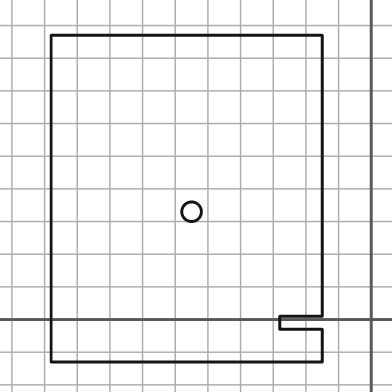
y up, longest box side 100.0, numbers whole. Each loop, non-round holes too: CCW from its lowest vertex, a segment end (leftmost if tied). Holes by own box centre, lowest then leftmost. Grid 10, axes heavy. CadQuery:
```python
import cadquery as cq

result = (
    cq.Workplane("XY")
    .moveTo(-98.0, -13.0)
    .lineTo(-15.0, -13.0)
    .lineTo(-15.0, -3.0)
    .lineTo(-28.0, -3.0)
    .lineTo(-28.0, 1.0)
    .lineTo(-15.0, 1.0)
    .lineTo(-15.0, 87.0)
    .lineTo(-98.0, 87.0)
    .close()
    .moveTo(-55.0, 33.0)
    .circle(3.0)
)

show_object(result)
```